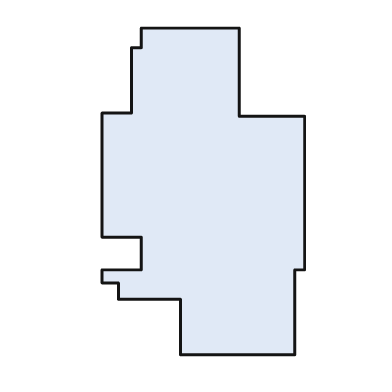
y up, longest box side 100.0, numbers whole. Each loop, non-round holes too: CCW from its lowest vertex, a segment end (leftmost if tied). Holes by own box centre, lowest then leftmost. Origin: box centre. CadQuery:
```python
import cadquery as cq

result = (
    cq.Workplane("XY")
    .moveTo(-7.0, -50.0)
    .lineTo(28.0, -50.0)
    .lineTo(28.0, -24.0)
    .lineTo(31.0, -24.0)
    .lineTo(31.0, 23.0)
    .lineTo(11.0, 23.0)
    .lineTo(11.0, 50.0)
    .lineTo(-19.0, 50.0)
    .lineTo(-19.0, 44.0)
    .lineTo(-22.0, 44.0)
    .lineTo(-22.0, 24.0)
    .lineTo(-31.0, 24.0)
    .lineTo(-31.0, -14.0)
    .lineTo(-19.0, -14.0)
    .lineTo(-19.0, -24.0)
    .lineTo(-31.0, -24.0)
    .lineTo(-31.0, -28.0)
    .lineTo(-26.0, -28.0)
    .lineTo(-26.0, -33.0)
    .lineTo(-7.0, -33.0)
    .close()
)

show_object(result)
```